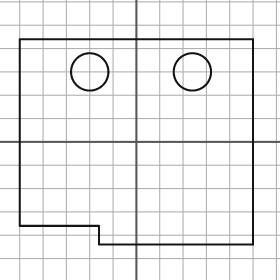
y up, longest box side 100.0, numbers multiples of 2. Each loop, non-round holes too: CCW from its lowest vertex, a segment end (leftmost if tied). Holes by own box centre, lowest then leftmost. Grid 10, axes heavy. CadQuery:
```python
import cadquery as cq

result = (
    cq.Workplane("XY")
    .moveTo(-16.0, -44.0)
    .lineTo(50.0, -44.0)
    .lineTo(50.0, 44.0)
    .lineTo(-50.0, 44.0)
    .lineTo(-50.0, -36.0)
    .lineTo(-16.0, -36.0)
    .close()
    .moveTo(-20.0, 30.0)
    .circle(8.0)
    .moveTo(24.0, 30.0)
    .circle(8.0)
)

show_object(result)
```